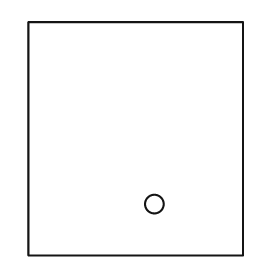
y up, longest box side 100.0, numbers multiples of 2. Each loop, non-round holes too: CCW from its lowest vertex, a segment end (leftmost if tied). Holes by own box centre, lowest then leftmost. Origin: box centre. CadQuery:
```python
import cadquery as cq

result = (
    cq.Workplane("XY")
    .moveTo(-46.0, -50.0)
    .lineTo(46.0, -50.0)
    .lineTo(46.0, 50.0)
    .lineTo(-46.0, 50.0)
    .close()
    .moveTo(8.0, -28.0)
    .circle(4.0)
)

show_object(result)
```